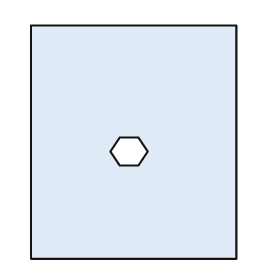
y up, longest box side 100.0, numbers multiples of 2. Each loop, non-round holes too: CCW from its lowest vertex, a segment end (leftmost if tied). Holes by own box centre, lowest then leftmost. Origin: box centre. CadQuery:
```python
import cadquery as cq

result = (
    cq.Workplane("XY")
    .moveTo(-44.0, -50.0)
    .lineTo(44.0, -50.0)
    .lineTo(44.0, 50.0)
    .lineTo(-44.0, 50.0)
    .close()
    .moveTo(-6.0, -10.0)
    .lineTo(2.0, -10.0)
    .lineTo(6.0, -4.0)
    .lineTo(2.0, 2.0)
    .lineTo(-6.0, 2.0)
    .lineTo(-10.0, -4.0)
    .close()
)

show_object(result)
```